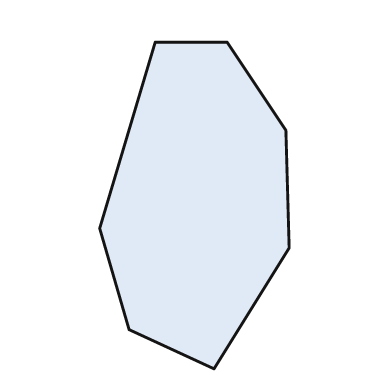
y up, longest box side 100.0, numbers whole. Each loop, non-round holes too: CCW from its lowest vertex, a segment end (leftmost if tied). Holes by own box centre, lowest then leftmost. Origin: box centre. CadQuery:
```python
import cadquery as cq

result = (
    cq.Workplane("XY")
    .moveTo(6.0, -50.0)
    .lineTo(29.0, -13.0)
    .lineTo(28.0, 23.0)
    .lineTo(10.0, 50.0)
    .lineTo(-12.0, 50.0)
    .lineTo(-29.0, -7.0)
    .lineTo(-20.0, -38.0)
    .close()
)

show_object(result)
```